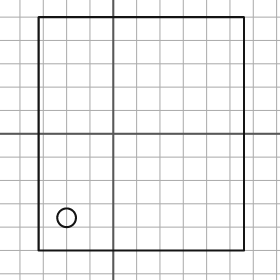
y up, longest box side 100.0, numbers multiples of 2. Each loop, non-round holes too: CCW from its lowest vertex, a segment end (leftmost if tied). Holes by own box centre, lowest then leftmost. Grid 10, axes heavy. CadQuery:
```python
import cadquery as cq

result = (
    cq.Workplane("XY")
    .moveTo(-32.0, -50.0)
    .lineTo(56.0, -50.0)
    .lineTo(56.0, 50.0)
    .lineTo(-32.0, 50.0)
    .close()
    .moveTo(-20.0, -36.0)
    .circle(4.0)
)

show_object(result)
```